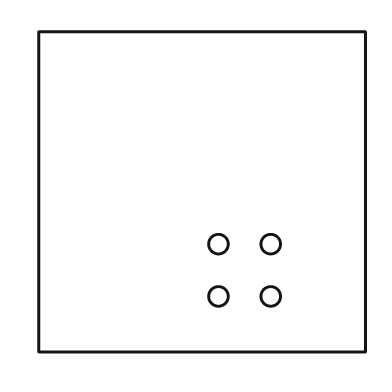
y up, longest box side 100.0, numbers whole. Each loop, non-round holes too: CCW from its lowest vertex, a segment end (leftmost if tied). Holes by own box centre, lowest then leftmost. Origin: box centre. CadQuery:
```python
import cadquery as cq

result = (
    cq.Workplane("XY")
    .moveTo(-50.0, -49.0)
    .lineTo(50.0, -49.0)
    .lineTo(50.0, 49.0)
    .lineTo(-50.0, 49.0)
    .close()
    .moveTo(5.0, -32.0)
    .circle(3.0)
    .moveTo(21.0, -32.0)
    .circle(3.0)
    .moveTo(5.0, -16.0)
    .circle(3.0)
    .moveTo(21.0, -16.0)
    .circle(3.0)
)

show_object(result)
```